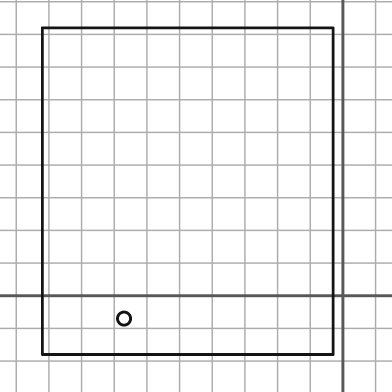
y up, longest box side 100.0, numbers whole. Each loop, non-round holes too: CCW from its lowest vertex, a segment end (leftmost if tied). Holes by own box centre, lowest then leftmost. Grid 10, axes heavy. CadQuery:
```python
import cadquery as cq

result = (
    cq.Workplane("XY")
    .moveTo(-92.0, -18.0)
    .lineTo(-3.0, -18.0)
    .lineTo(-3.0, 82.0)
    .lineTo(-92.0, 82.0)
    .close()
    .moveTo(-67.0, -7.0)
    .circle(2.0)
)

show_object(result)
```